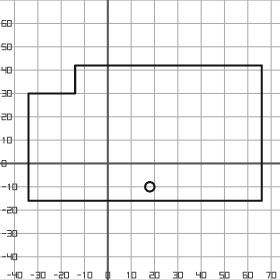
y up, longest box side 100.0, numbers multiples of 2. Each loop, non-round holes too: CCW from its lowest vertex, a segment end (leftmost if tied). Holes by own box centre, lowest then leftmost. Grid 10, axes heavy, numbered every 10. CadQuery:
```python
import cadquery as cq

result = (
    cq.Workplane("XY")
    .moveTo(-34.0, -16.0)
    .lineTo(66.0, -16.0)
    .lineTo(66.0, 42.0)
    .lineTo(-14.0, 42.0)
    .lineTo(-14.0, 30.0)
    .lineTo(-34.0, 30.0)
    .close()
    .moveTo(18.0, -10.0)
    .circle(2.0)
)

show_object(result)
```